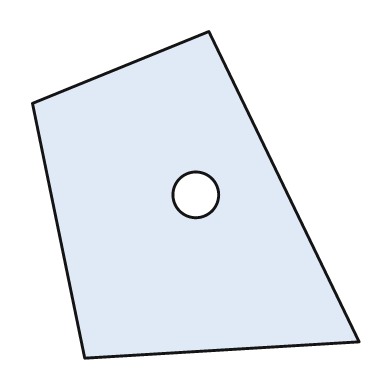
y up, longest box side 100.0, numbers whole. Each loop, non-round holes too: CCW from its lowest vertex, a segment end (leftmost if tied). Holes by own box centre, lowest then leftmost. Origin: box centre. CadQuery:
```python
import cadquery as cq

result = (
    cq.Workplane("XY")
    .moveTo(-34.0, -50.0)
    .lineTo(50.0, -45.0)
    .lineTo(4.0, 50.0)
    .lineTo(-50.0, 28.0)
    .close()
    .moveTo(0.0, 0.0)
    .circle(7.0)
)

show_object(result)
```